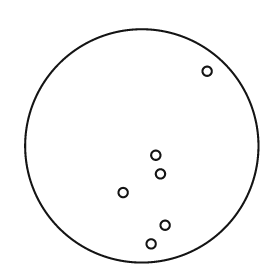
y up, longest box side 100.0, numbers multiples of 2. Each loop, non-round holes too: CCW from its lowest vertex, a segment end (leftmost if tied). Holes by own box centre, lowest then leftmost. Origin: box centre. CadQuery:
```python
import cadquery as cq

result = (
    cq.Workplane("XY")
    .moveTo(0.0, 0.0)
    .circle(50.0)
    .moveTo(4.0, -42.0)
    .circle(2.0)
    .moveTo(10.0, -34.0)
    .circle(2.0)
    .moveTo(-8.0, -20.0)
    .circle(2.0)
    .moveTo(8.0, -12.0)
    .circle(2.0)
    .moveTo(6.0, -4.0)
    .circle(2.0)
    .moveTo(28.0, 32.0)
    .circle(2.0)
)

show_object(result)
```